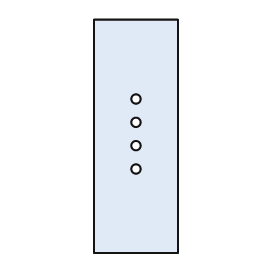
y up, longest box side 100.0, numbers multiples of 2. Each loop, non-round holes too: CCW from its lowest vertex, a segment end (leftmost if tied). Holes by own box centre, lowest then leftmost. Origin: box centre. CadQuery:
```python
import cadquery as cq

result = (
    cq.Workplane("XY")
    .moveTo(-18.0, -50.0)
    .lineTo(18.0, -50.0)
    .lineTo(18.0, 50.0)
    .lineTo(-18.0, 50.0)
    .close()
    .moveTo(0.0, -14.0)
    .circle(2.0)
    .moveTo(0.0, -4.0)
    .circle(2.0)
    .moveTo(0.0, 6.0)
    .circle(2.0)
    .moveTo(0.0, 16.0)
    .circle(2.0)
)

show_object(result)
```